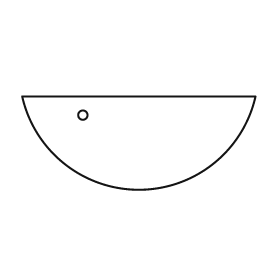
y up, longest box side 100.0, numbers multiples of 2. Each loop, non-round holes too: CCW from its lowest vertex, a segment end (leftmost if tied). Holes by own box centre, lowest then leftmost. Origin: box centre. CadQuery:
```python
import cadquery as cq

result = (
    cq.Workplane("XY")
    .moveTo(-50.0, 20.0)
    .threePointArc((0.0, -20.0), (50.0, 20.0))
    .close()
    .moveTo(-24.0, 12.0)
    .circle(2.0)
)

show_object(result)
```